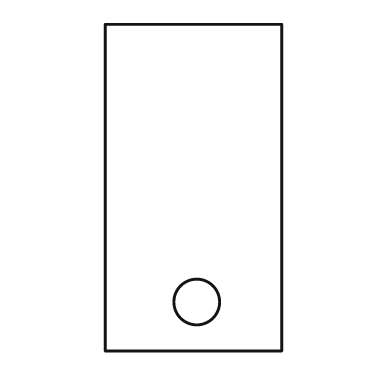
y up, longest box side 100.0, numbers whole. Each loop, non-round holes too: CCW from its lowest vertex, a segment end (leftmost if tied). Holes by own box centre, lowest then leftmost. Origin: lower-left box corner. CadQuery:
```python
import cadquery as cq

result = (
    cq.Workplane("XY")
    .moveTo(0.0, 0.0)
    .lineTo(54.0, 0.0)
    .lineTo(54.0, 100.0)
    .lineTo(0.0, 100.0)
    .close()
    .moveTo(28.0, 15.0)
    .circle(7.0)
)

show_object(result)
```